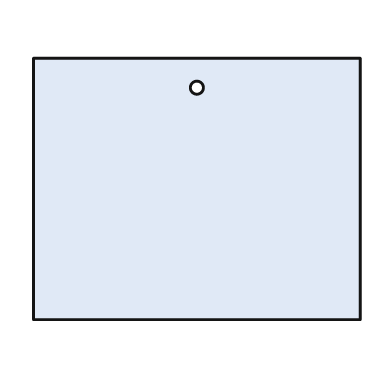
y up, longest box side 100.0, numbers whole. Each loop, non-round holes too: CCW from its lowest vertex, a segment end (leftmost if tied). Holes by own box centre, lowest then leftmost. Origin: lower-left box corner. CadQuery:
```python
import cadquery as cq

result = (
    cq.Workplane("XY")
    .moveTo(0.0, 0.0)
    .lineTo(100.0, 0.0)
    .lineTo(100.0, 80.0)
    .lineTo(0.0, 80.0)
    .close()
    .moveTo(50.0, 71.0)
    .circle(2.0)
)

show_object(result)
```